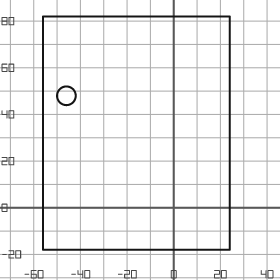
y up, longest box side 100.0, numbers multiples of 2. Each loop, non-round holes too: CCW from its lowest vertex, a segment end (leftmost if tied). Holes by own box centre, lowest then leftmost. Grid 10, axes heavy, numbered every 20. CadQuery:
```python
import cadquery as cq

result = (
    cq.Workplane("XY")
    .moveTo(-56.0, -18.0)
    .lineTo(24.0, -18.0)
    .lineTo(24.0, 82.0)
    .lineTo(-56.0, 82.0)
    .close()
    .moveTo(-46.0, 48.0)
    .circle(4.0)
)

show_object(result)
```